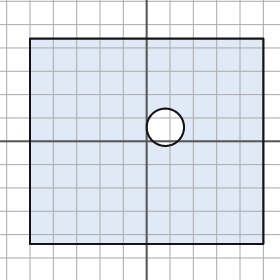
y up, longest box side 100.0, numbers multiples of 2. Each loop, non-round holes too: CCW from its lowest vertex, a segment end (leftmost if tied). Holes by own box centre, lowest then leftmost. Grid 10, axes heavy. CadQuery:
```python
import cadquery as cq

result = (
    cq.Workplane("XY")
    .moveTo(-50.0, -44.0)
    .lineTo(50.0, -44.0)
    .lineTo(50.0, 44.0)
    .lineTo(-50.0, 44.0)
    .close()
    .moveTo(8.0, 6.0)
    .circle(8.0)
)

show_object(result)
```